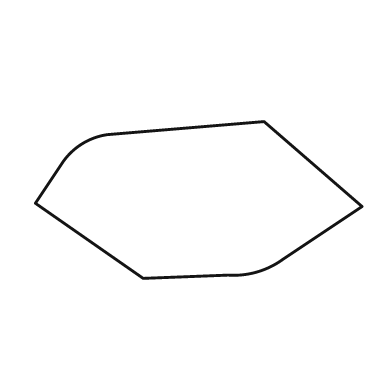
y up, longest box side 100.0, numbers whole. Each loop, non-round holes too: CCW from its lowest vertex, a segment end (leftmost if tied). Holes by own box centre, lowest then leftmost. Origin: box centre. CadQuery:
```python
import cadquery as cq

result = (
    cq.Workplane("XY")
    .moveTo(-17.0, -24.0)
    .lineTo(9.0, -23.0)
    .threePointArc((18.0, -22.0), (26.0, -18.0))
    .lineTo(50.0, -2.0)
    .lineTo(20.0, 24.0)
    .lineTo(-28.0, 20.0)
    .threePointArc((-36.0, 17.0), (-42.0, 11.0))
    .lineTo(-50.0, -1.0)
    .close()
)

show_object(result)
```